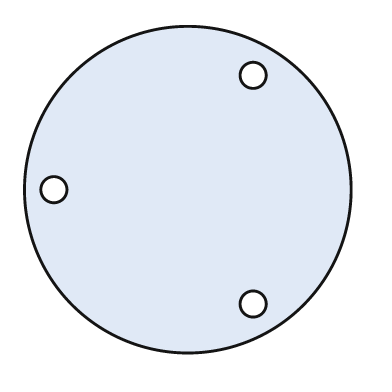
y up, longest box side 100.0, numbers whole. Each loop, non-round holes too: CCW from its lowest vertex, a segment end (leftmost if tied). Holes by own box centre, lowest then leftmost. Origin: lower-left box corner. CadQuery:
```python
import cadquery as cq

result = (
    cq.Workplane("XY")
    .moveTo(50.0, 50.0)
    .circle(50.0)
    .moveTo(70.0, 15.0)
    .circle(4.0)
    .moveTo(9.0, 50.0)
    .circle(4.0)
    .moveTo(70.0, 85.0)
    .circle(4.0)
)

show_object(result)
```